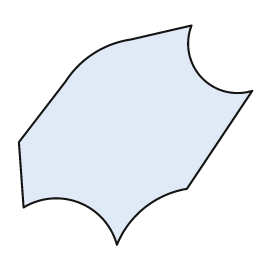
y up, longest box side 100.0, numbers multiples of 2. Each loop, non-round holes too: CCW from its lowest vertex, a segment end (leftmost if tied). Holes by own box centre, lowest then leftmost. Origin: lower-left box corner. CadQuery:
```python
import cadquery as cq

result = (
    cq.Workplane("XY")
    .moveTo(42.0, 0.0)
    .threePointArc((54.0, 16.0), (72.0, 24.0))
    .lineTo(100.0, 66.0)
    .threePointArc((78.0, 72.0), (74.0, 94.0))
    .lineTo(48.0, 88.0)
    .threePointArc((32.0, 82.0), (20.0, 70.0))
    .lineTo(0.0, 44.0)
    .lineTo(2.0, 16.0)
    .threePointArc((26.0, 18.0), (42.0, 0.0))
    .close()
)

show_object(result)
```